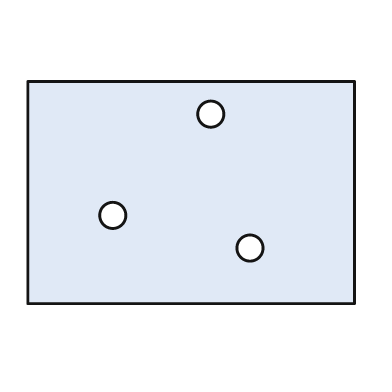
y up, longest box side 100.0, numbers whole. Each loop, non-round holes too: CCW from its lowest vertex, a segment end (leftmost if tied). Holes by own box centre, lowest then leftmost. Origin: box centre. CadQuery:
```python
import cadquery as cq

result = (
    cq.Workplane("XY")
    .moveTo(-50.0, -34.0)
    .lineTo(50.0, -34.0)
    .lineTo(50.0, 34.0)
    .lineTo(-50.0, 34.0)
    .close()
    .moveTo(18.0, -17.0)
    .circle(4.0)
    .moveTo(-24.0, -7.0)
    .circle(4.0)
    .moveTo(6.0, 24.0)
    .circle(4.0)
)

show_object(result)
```